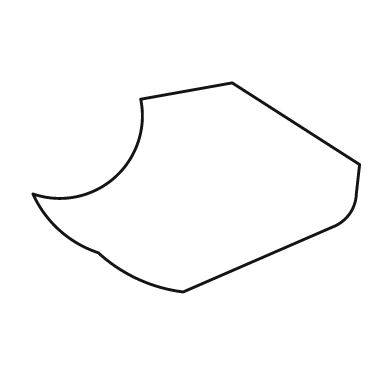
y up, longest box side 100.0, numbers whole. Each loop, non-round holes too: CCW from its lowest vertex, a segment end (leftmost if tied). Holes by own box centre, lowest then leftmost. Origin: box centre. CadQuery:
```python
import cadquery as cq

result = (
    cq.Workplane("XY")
    .moveTo(-4.0, -32.0)
    .lineTo(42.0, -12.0)
    .threePointArc((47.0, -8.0), (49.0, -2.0))
    .lineTo(50.0, 7.0)
    .lineTo(11.0, 32.0)
    .lineTo(-17.0, 27.0)
    .threePointArc((-25.0, 3.0), (-50.0, -2.0))
    .threePointArc((-42.0, -13.0), (-30.0, -20.0))
    .threePointArc((-18.0, -28.0), (-4.0, -32.0))
    .close()
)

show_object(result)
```